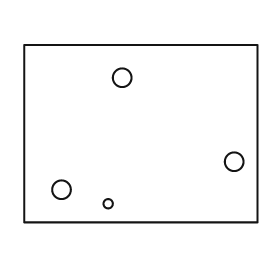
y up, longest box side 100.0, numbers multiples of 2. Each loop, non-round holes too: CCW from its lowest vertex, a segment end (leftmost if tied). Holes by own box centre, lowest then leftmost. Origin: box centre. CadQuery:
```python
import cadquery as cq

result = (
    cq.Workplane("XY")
    .moveTo(-50.0, -38.0)
    .lineTo(50.0, -38.0)
    .lineTo(50.0, 38.0)
    .lineTo(-50.0, 38.0)
    .close()
    .moveTo(-14.0, -30.0)
    .circle(2.0)
    .moveTo(-34.0, -24.0)
    .circle(4.0)
    .moveTo(40.0, -12.0)
    .circle(4.0)
    .moveTo(-8.0, 24.0)
    .circle(4.0)
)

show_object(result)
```